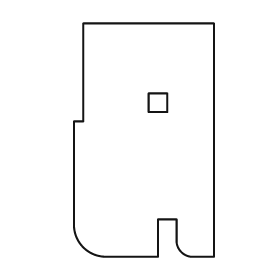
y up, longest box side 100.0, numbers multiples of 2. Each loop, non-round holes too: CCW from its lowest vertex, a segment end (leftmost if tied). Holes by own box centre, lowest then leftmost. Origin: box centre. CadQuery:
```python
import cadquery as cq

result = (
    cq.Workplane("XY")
    .moveTo(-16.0, -50.0)
    .lineTo(6.0, -50.0)
    .lineTo(6.0, -34.0)
    .lineTo(14.0, -34.0)
    .lineTo(14.0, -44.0)
    .threePointArc((16.0, -48.0), (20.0, -50.0))
    .lineTo(30.0, -50.0)
    .lineTo(30.0, 50.0)
    .lineTo(-26.0, 50.0)
    .lineTo(-26.0, 8.0)
    .lineTo(-30.0, 8.0)
    .lineTo(-30.0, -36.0)
    .threePointArc((-26.0, -46.0), (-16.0, -50.0))
    .close()
    .moveTo(2.0, 12.0)
    .lineTo(10.0, 12.0)
    .lineTo(10.0, 20.0)
    .lineTo(2.0, 20.0)
    .close()
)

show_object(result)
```